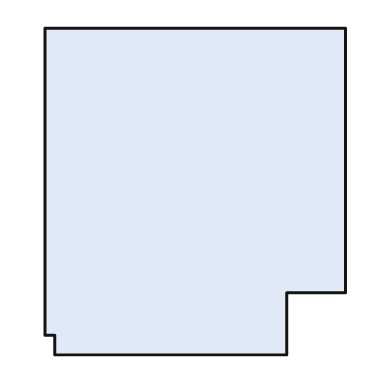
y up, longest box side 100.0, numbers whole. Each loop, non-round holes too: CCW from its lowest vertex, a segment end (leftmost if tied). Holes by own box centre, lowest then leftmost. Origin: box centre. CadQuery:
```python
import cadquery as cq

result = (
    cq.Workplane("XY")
    .moveTo(-43.0, -50.0)
    .lineTo(28.0, -50.0)
    .lineTo(28.0, -31.0)
    .lineTo(46.0, -31.0)
    .lineTo(46.0, 50.0)
    .lineTo(-46.0, 50.0)
    .lineTo(-46.0, -44.0)
    .lineTo(-43.0, -44.0)
    .close()
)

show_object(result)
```